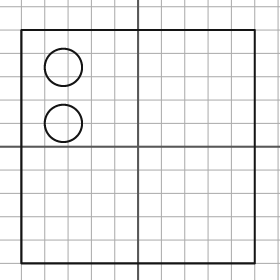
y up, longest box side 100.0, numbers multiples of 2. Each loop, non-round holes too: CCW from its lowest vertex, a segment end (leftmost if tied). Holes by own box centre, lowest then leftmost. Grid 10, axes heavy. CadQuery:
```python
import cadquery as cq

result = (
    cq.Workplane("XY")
    .moveTo(-50.0, -50.0)
    .lineTo(50.0, -50.0)
    .lineTo(50.0, 50.0)
    .lineTo(-50.0, 50.0)
    .close()
    .moveTo(-32.0, 10.0)
    .circle(8.0)
    .moveTo(-32.0, 34.0)
    .circle(8.0)
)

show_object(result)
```